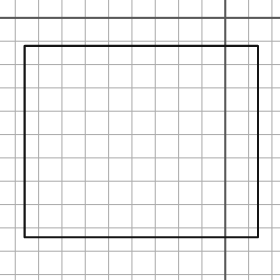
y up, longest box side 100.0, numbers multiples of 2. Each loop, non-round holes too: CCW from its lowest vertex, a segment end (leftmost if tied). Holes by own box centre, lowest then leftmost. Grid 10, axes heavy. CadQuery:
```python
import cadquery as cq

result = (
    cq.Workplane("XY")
    .moveTo(-86.0, -94.0)
    .lineTo(14.0, -94.0)
    .lineTo(14.0, -12.0)
    .lineTo(-86.0, -12.0)
    .close()
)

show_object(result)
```